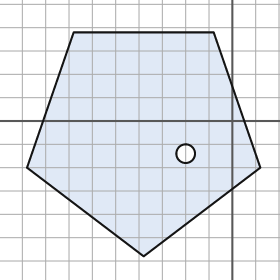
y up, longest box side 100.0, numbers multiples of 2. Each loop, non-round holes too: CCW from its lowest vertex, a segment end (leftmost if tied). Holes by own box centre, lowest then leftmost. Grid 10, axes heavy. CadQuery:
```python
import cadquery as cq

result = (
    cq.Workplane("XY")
    .moveTo(-38.0, -58.0)
    .lineTo(12.0, -20.0)
    .lineTo(-8.0, 38.0)
    .lineTo(-68.0, 38.0)
    .lineTo(-88.0, -20.0)
    .close()
    .moveTo(-20.0, -14.0)
    .circle(4.0)
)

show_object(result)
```